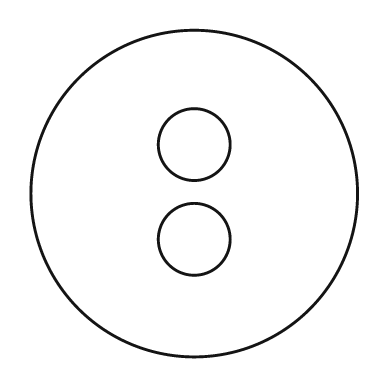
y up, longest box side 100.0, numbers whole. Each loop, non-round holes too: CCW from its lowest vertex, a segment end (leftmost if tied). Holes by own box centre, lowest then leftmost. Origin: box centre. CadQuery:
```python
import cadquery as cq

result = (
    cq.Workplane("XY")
    .moveTo(0.0, 0.0)
    .circle(50.0)
    .moveTo(0.0, -14.0)
    .circle(11.0)
    .moveTo(0.0, 15.0)
    .circle(11.0)
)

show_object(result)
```